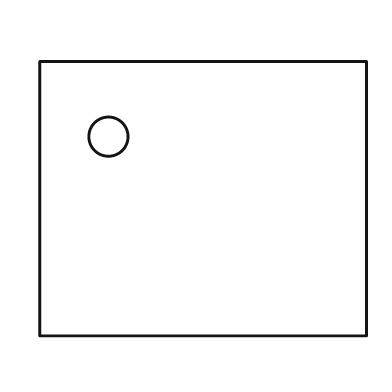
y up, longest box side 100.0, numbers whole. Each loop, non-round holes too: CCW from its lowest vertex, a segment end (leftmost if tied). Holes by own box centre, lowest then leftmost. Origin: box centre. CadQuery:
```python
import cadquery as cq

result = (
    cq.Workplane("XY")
    .moveTo(-50.0, -42.0)
    .lineTo(50.0, -42.0)
    .lineTo(50.0, 42.0)
    .lineTo(-50.0, 42.0)
    .close()
    .moveTo(-29.0, 19.0)
    .circle(6.0)
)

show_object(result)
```